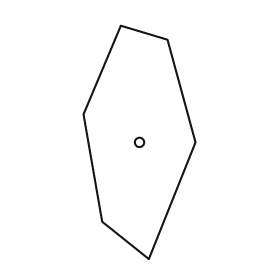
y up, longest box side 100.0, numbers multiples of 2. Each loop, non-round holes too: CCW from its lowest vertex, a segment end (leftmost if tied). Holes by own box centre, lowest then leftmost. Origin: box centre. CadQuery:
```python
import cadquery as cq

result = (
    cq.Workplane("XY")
    .moveTo(4.0, -50.0)
    .lineTo(24.0, 0.0)
    .lineTo(12.0, 44.0)
    .lineTo(-8.0, 50.0)
    .lineTo(-24.0, 12.0)
    .lineTo(-16.0, -34.0)
    .close()
    .moveTo(0.0, 0.0)
    .circle(2.0)
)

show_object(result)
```